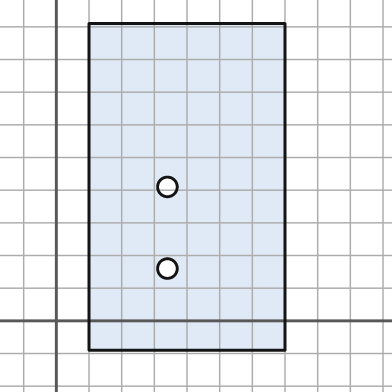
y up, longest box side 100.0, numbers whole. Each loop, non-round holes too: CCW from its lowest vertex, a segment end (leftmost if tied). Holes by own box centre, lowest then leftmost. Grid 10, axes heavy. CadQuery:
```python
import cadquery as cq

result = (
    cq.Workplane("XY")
    .moveTo(10.0, -9.0)
    .lineTo(70.0, -9.0)
    .lineTo(70.0, 91.0)
    .lineTo(10.0, 91.0)
    .close()
    .moveTo(34.0, 16.0)
    .circle(3.0)
    .moveTo(34.0, 41.0)
    .circle(3.0)
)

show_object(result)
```